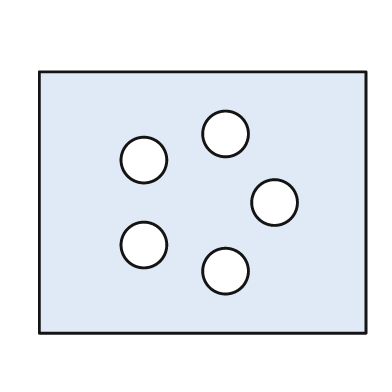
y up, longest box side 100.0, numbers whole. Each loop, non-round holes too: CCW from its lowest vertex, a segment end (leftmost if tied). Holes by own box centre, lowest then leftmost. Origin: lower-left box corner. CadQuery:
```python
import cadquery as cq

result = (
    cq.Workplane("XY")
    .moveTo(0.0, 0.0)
    .lineTo(100.0, 0.0)
    .lineTo(100.0, 80.0)
    .lineTo(0.0, 80.0)
    .close()
    .moveTo(57.0, 19.0)
    .circle(7.0)
    .moveTo(32.0, 27.0)
    .circle(7.0)
    .moveTo(72.0, 40.0)
    .circle(7.0)
    .moveTo(32.0, 53.0)
    .circle(7.0)
    .moveTo(57.0, 61.0)
    .circle(7.0)
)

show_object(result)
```